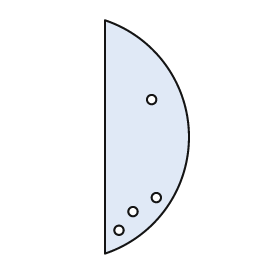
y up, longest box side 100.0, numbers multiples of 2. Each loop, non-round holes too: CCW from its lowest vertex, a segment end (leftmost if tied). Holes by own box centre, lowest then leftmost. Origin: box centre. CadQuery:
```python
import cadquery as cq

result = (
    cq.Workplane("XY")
    .moveTo(-18.0, -50.0)
    .threePointArc((18.0, 0.0), (-18.0, 50.0))
    .close()
    .moveTo(-12.0, -40.0)
    .circle(2.0)
    .moveTo(-6.0, -32.0)
    .circle(2.0)
    .moveTo(4.0, -26.0)
    .circle(2.0)
    .moveTo(2.0, 16.0)
    .circle(2.0)
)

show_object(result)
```